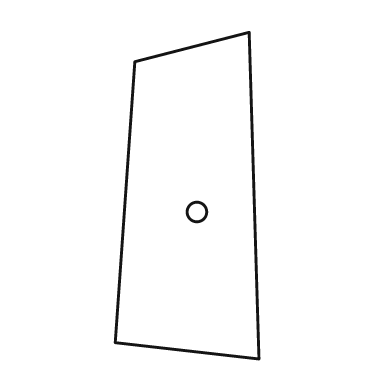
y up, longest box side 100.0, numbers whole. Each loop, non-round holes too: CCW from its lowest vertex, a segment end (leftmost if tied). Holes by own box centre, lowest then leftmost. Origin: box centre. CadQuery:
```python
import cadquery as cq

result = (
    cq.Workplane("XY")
    .moveTo(22.0, -50.0)
    .lineTo(19.0, 50.0)
    .lineTo(-16.0, 41.0)
    .lineTo(-22.0, -45.0)
    .close()
    .moveTo(3.0, -5.0)
    .circle(3.0)
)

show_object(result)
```